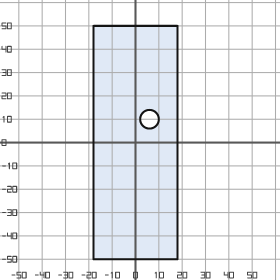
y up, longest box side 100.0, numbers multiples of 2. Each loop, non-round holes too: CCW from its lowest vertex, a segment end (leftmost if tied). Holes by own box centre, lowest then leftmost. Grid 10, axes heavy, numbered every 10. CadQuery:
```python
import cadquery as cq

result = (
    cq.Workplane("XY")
    .moveTo(-18.0, -50.0)
    .lineTo(18.0, -50.0)
    .lineTo(18.0, 50.0)
    .lineTo(-18.0, 50.0)
    .close()
    .moveTo(6.0, 10.0)
    .circle(4.0)
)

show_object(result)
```